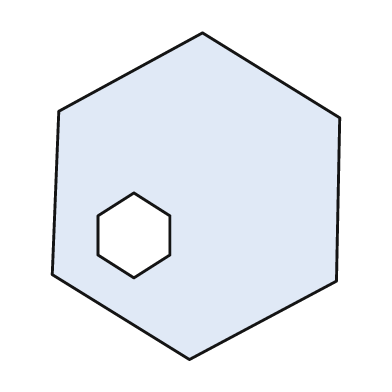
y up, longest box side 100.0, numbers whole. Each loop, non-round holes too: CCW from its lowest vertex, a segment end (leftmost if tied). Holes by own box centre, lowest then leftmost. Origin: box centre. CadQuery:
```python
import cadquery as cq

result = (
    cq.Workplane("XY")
    .moveTo(-2.0, -50.0)
    .lineTo(43.0, -26.0)
    .lineTo(44.0, 24.0)
    .lineTo(2.0, 50.0)
    .lineTo(-42.0, 26.0)
    .lineTo(-44.0, -24.0)
    .close()
    .moveTo(-19.0, -25.0)
    .lineTo(-8.0, -18.0)
    .lineTo(-8.0, -6.0)
    .lineTo(-19.0, 1.0)
    .lineTo(-30.0, -6.0)
    .lineTo(-30.0, -18.0)
    .close()
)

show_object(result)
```